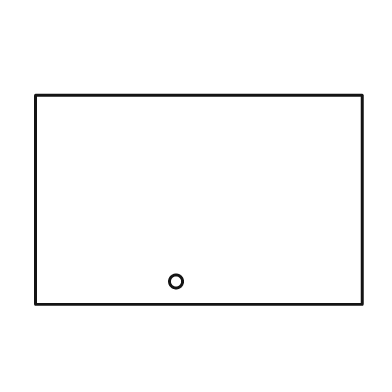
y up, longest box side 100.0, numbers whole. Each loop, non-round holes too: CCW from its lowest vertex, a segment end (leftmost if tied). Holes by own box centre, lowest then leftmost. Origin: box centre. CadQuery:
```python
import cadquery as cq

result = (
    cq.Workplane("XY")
    .moveTo(-50.0, -32.0)
    .lineTo(50.0, -32.0)
    .lineTo(50.0, 32.0)
    .lineTo(-50.0, 32.0)
    .close()
    .moveTo(-7.0, -25.0)
    .circle(2.0)
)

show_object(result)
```